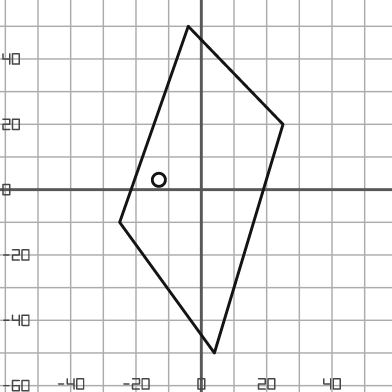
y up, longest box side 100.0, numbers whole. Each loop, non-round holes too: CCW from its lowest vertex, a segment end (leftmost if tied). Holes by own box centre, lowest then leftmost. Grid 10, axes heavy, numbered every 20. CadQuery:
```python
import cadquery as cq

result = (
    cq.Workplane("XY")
    .moveTo(4.0, -50.0)
    .lineTo(25.0, 20.0)
    .lineTo(-4.0, 50.0)
    .lineTo(-25.0, -10.0)
    .close()
    .moveTo(-13.0, 3.0)
    .circle(2.0)
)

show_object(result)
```